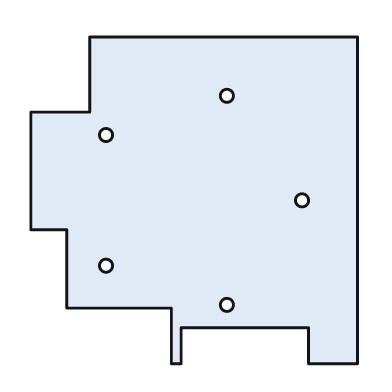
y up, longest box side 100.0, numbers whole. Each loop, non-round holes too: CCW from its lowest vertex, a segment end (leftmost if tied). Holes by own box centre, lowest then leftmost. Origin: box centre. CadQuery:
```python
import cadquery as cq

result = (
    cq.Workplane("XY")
    .moveTo(-7.0, -50.0)
    .lineTo(-4.0, -50.0)
    .lineTo(-4.0, -39.0)
    .lineTo(35.0, -39.0)
    .lineTo(35.0, -50.0)
    .lineTo(50.0, -50.0)
    .lineTo(50.0, 50.0)
    .lineTo(-32.0, 50.0)
    .lineTo(-32.0, 27.0)
    .lineTo(-50.0, 27.0)
    .lineTo(-50.0, -9.0)
    .lineTo(-39.0, -9.0)
    .lineTo(-39.0, -33.0)
    .lineTo(-7.0, -33.0)
    .close()
    .moveTo(10.0, -32.0)
    .circle(2.0)
    .moveTo(-27.0, -20.0)
    .circle(2.0)
    .moveTo(33.0, 0.0)
    .circle(2.0)
    .moveTo(-27.0, 20.0)
    .circle(2.0)
    .moveTo(10.0, 32.0)
    .circle(2.0)
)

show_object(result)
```